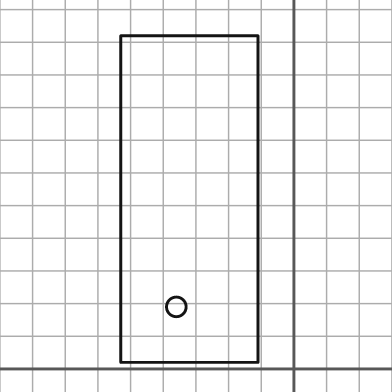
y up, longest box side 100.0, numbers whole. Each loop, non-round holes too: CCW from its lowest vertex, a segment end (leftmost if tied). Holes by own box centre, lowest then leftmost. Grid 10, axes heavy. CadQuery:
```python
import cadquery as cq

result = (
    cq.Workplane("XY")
    .moveTo(-53.0, 2.0)
    .lineTo(-11.0, 2.0)
    .lineTo(-11.0, 102.0)
    .lineTo(-53.0, 102.0)
    .close()
    .moveTo(-36.0, 19.0)
    .circle(3.0)
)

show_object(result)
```